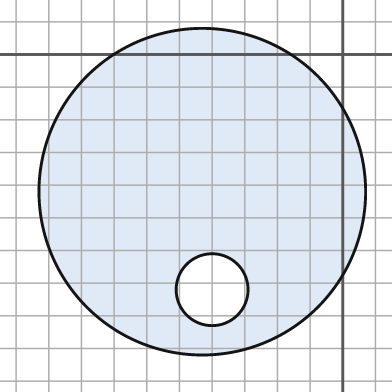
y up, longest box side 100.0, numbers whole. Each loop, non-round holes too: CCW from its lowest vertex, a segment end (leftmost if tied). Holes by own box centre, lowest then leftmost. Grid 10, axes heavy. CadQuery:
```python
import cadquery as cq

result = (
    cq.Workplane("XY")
    .moveTo(-43.0, -42.0)
    .circle(50.0)
    .moveTo(-40.0, -72.0)
    .circle(11.0)
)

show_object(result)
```